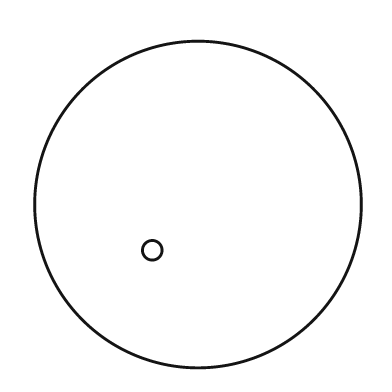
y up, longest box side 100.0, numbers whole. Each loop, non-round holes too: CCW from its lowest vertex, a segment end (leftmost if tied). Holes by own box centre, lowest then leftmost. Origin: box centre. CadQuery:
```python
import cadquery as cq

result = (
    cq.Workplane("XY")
    .moveTo(0.0, 0.0)
    .circle(50.0)
    .moveTo(-14.0, -14.0)
    .circle(3.0)
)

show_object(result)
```